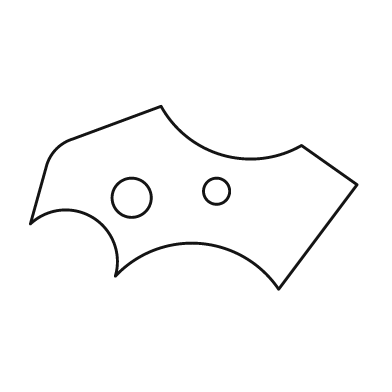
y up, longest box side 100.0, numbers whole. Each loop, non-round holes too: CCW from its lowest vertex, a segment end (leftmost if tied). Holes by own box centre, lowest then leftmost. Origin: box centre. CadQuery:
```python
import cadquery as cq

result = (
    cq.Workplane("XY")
    .moveTo(26.0, -28.0)
    .lineTo(50.0, 4.0)
    .lineTo(33.0, 16.0)
    .threePointArc((9.0, 13.0), (-10.0, 28.0))
    .lineTo(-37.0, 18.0)
    .threePointArc((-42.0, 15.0), (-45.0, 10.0))
    .lineTo(-50.0, -8.0)
    .threePointArc((-31.0, -6.0), (-24.0, -24.0))
    .threePointArc((2.0, -14.0), (26.0, -28.0))
    .close()
    .moveTo(-19.0, 0.0)
    .circle(6.0)
    .moveTo(7.0, 2.0)
    .circle(4.0)
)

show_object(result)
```